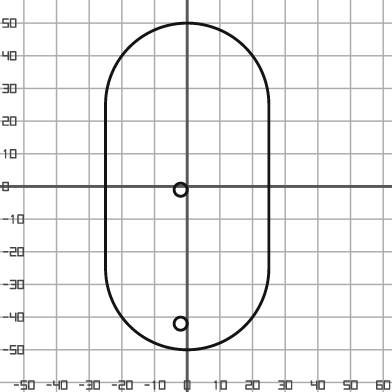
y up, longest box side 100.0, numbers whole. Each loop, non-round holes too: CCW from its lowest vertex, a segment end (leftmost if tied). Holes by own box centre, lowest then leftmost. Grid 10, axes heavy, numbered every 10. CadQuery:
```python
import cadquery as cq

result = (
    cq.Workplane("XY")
    .moveTo(-25.0, -25.0)
    .threePointArc((0.0, -50.0), (25.0, -25.0))
    .lineTo(25.0, 25.0)
    .threePointArc((0.0, 50.0), (-25.0, 25.0))
    .close()
    .moveTo(-2.0, -42.0)
    .circle(2.0)
    .moveTo(-2.0, -1.0)
    .circle(2.0)
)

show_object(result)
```